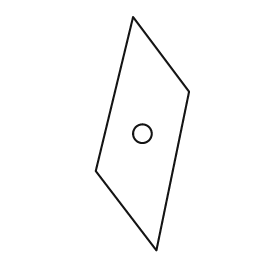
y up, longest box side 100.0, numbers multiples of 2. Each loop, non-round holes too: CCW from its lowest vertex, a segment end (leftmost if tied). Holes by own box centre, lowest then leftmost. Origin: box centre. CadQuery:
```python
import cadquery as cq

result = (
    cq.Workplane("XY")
    .moveTo(6.0, -50.0)
    .lineTo(20.0, 18.0)
    .lineTo(-4.0, 50.0)
    .lineTo(-20.0, -16.0)
    .close()
    .moveTo(0.0, 0.0)
    .circle(4.0)
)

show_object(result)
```